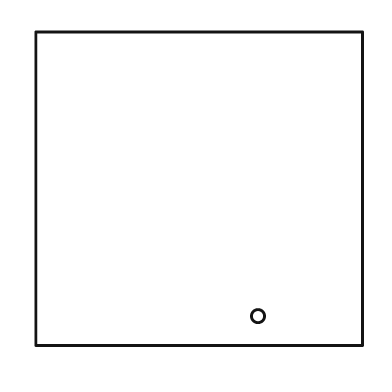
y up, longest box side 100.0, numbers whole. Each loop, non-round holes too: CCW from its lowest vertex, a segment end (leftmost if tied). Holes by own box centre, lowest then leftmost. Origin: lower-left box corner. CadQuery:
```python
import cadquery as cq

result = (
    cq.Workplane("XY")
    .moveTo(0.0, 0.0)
    .lineTo(100.0, 0.0)
    .lineTo(100.0, 96.0)
    .lineTo(0.0, 96.0)
    .close()
    .moveTo(68.0, 9.0)
    .circle(2.0)
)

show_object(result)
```